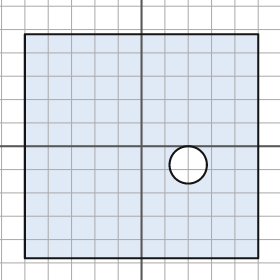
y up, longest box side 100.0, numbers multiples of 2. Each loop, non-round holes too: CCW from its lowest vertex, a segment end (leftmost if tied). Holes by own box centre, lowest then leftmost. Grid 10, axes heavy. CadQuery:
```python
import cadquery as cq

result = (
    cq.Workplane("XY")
    .moveTo(-50.0, -48.0)
    .lineTo(50.0, -48.0)
    .lineTo(50.0, 48.0)
    .lineTo(-50.0, 48.0)
    .close()
    .moveTo(20.0, -8.0)
    .circle(8.0)
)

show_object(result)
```